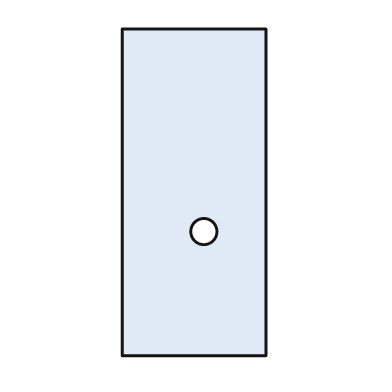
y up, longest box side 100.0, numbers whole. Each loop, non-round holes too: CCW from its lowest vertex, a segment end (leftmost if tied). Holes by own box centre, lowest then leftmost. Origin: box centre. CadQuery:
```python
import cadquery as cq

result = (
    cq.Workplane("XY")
    .moveTo(-22.0, -50.0)
    .lineTo(22.0, -50.0)
    .lineTo(22.0, 50.0)
    .lineTo(-22.0, 50.0)
    .close()
    .moveTo(3.0, -12.0)
    .circle(4.0)
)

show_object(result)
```